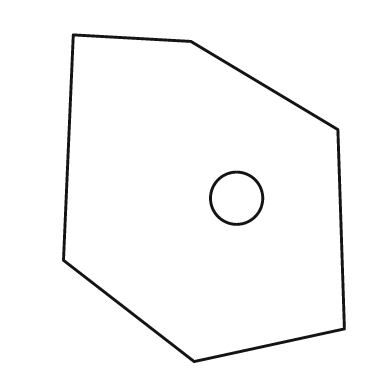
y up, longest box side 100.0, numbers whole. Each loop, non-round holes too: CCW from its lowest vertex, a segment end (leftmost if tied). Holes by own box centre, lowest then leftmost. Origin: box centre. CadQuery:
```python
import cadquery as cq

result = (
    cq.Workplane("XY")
    .moveTo(-3.0, -50.0)
    .lineTo(43.0, -40.0)
    .lineTo(41.0, 21.0)
    .lineTo(-4.0, 48.0)
    .lineTo(-40.0, 50.0)
    .lineTo(-43.0, -19.0)
    .close()
    .moveTo(10.0, 0.0)
    .circle(8.0)
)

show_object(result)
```